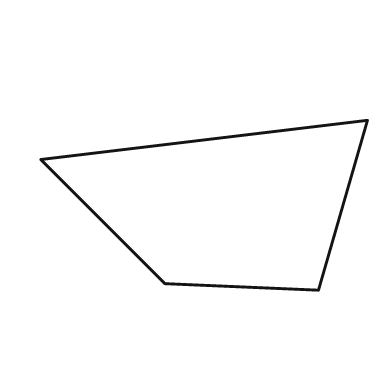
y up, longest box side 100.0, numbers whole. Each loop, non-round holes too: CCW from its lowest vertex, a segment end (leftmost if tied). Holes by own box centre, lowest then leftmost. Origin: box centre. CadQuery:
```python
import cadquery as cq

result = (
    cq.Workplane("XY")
    .moveTo(35.0, -26.0)
    .lineTo(50.0, 26.0)
    .lineTo(-50.0, 14.0)
    .lineTo(-12.0, -24.0)
    .close()
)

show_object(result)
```